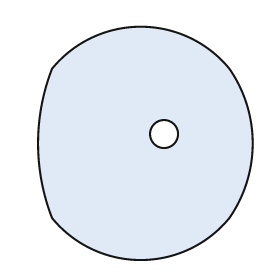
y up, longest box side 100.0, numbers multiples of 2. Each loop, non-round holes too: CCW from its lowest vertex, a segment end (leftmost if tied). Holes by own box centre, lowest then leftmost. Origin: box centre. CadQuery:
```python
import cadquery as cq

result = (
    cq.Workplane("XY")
    .moveTo(-40.0, -32.0)
    .threePointArc((-2.0, -50.0), (36.0, -32.0))
    .threePointArc((46.0, 0.0), (36.0, 32.0))
    .threePointArc((-2.0, 50.0), (-40.0, 32.0))
    .threePointArc((-46.0, 0.0), (-40.0, -32.0))
    .close()
    .moveTo(8.0, 4.0)
    .circle(6.0)
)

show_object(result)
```